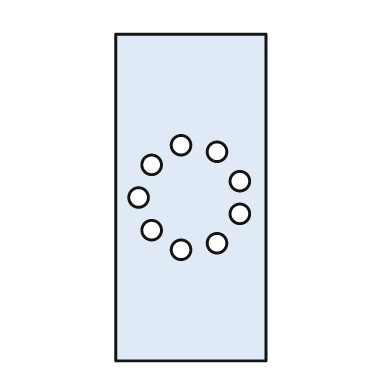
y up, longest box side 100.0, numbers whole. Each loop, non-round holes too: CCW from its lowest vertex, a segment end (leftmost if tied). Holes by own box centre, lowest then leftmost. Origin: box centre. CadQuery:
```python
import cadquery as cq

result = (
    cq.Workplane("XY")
    .moveTo(-23.0, -50.0)
    .lineTo(23.0, -50.0)
    .lineTo(23.0, 50.0)
    .lineTo(-23.0, 50.0)
    .close()
    .moveTo(-3.0, -16.0)
    .circle(3.0)
    .moveTo(8.0, -14.0)
    .circle(3.0)
    .moveTo(-12.0, -10.0)
    .circle(3.0)
    .moveTo(15.0, -5.0)
    .circle(3.0)
    .moveTo(-16.0, 0.0)
    .circle(3.0)
    .moveTo(15.0, 5.0)
    .circle(3.0)
    .moveTo(-12.0, 10.0)
    .circle(3.0)
    .moveTo(8.0, 14.0)
    .circle(3.0)
    .moveTo(-3.0, 16.0)
    .circle(3.0)
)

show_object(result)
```